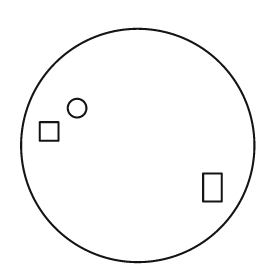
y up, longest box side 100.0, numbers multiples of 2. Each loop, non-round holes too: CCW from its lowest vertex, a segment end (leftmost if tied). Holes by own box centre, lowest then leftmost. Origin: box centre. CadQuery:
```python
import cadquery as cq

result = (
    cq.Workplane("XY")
    .moveTo(0.0, 0.0)
    .circle(50.0)
    .moveTo(28.0, -24.0)
    .lineTo(36.0, -24.0)
    .lineTo(36.0, -12.0)
    .lineTo(28.0, -12.0)
    .close()
    .moveTo(-42.0, 2.0)
    .lineTo(-34.0, 2.0)
    .lineTo(-34.0, 10.0)
    .lineTo(-42.0, 10.0)
    .close()
    .moveTo(-26.0, 16.0)
    .circle(4.0)
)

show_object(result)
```